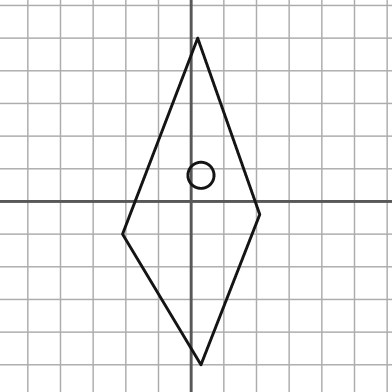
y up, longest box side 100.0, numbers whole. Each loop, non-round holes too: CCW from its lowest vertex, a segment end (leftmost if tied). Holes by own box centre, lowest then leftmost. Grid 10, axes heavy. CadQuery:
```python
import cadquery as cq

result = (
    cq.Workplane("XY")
    .moveTo(3.0, -50.0)
    .lineTo(21.0, -4.0)
    .lineTo(2.0, 50.0)
    .lineTo(-21.0, -10.0)
    .close()
    .moveTo(3.0, 8.0)
    .circle(4.0)
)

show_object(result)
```